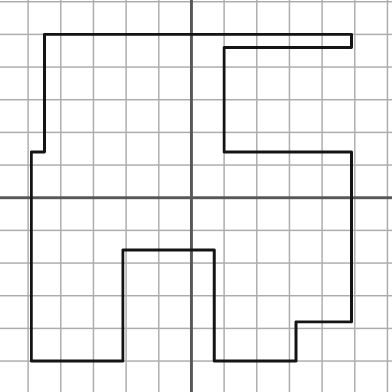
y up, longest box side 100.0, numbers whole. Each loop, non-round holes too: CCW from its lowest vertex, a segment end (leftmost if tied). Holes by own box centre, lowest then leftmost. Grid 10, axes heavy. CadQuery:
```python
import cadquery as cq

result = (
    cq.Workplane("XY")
    .moveTo(-49.0, -50.0)
    .lineTo(-21.0, -50.0)
    .lineTo(-21.0, -16.0)
    .lineTo(7.0, -16.0)
    .lineTo(7.0, -50.0)
    .lineTo(32.0, -50.0)
    .lineTo(32.0, -38.0)
    .lineTo(49.0, -38.0)
    .lineTo(49.0, 14.0)
    .lineTo(10.0, 14.0)
    .lineTo(10.0, 46.0)
    .lineTo(49.0, 46.0)
    .lineTo(49.0, 50.0)
    .lineTo(-45.0, 50.0)
    .lineTo(-45.0, 14.0)
    .lineTo(-49.0, 14.0)
    .close()
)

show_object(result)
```